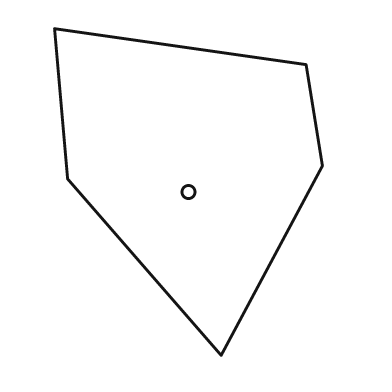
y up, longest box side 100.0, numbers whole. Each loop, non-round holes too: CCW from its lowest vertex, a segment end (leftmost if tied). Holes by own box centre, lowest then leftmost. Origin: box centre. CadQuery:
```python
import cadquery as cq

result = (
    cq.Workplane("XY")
    .moveTo(10.0, -50.0)
    .lineTo(41.0, 8.0)
    .lineTo(36.0, 39.0)
    .lineTo(-41.0, 50.0)
    .lineTo(-37.0, 4.0)
    .close()
    .moveTo(0.0, 0.0)
    .circle(2.0)
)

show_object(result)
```